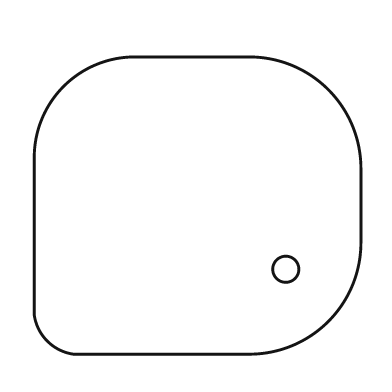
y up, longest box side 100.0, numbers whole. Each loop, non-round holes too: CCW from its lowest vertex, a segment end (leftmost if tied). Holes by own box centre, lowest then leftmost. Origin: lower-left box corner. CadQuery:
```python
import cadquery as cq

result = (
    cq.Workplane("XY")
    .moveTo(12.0, 0.0)
    .lineTo(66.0, 0.0)
    .threePointArc((90.0, 10.0), (100.0, 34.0))
    .lineTo(100.0, 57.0)
    .threePointArc((90.0, 81.0), (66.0, 91.0))
    .lineTo(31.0, 91.0)
    .threePointArc((9.0, 82.0), (0.0, 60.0))
    .lineTo(0.0, 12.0)
    .threePointArc((4.0, 4.0), (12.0, 0.0))
    .close()
    .moveTo(77.0, 26.0)
    .circle(4.0)
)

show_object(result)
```